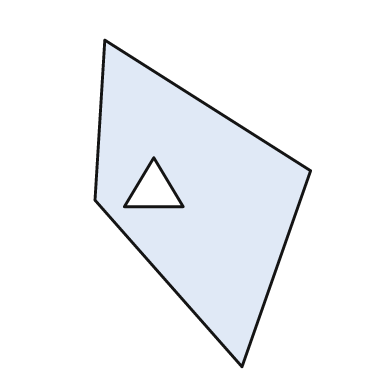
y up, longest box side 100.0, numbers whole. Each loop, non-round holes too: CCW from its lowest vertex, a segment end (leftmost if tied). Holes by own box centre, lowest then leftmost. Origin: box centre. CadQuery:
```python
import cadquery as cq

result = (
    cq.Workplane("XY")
    .moveTo(12.0, -50.0)
    .lineTo(33.0, 10.0)
    .lineTo(-30.0, 50.0)
    .lineTo(-33.0, 1.0)
    .close()
    .moveTo(-24.0, -1.0)
    .lineTo(-6.0, -1.0)
    .lineTo(-15.0, 14.0)
    .close()
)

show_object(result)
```